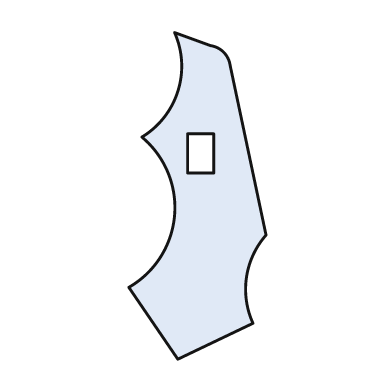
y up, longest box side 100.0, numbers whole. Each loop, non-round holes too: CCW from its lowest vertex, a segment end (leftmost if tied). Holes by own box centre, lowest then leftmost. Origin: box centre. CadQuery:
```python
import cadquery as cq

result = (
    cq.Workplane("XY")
    .moveTo(-6.0, -50.0)
    .lineTo(17.0, -39.0)
    .threePointArc((15.0, -25.0), (21.0, -12.0))
    .lineTo(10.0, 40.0)
    .threePointArc((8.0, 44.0), (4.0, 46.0))
    .lineTo(-7.0, 50.0)
    .threePointArc((-6.0, 32.0), (-17.0, 18.0))
    .threePointArc((-7.0, -6.0), (-21.0, -28.0))
    .close()
    .moveTo(-3.0, 7.0)
    .lineTo(5.0, 7.0)
    .lineTo(5.0, 19.0)
    .lineTo(-3.0, 19.0)
    .close()
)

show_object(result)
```